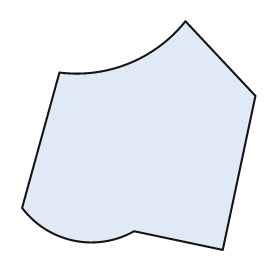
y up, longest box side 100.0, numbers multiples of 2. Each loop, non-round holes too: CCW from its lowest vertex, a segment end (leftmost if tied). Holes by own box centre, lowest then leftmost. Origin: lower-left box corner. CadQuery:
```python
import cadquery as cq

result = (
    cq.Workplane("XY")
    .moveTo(86.0, 0.0)
    .lineTo(100.0, 66.0)
    .lineTo(70.0, 98.0)
    .threePointArc((46.0, 80.0), (16.0, 76.0))
    .lineTo(0.0, 18.0)
    .threePointArc((22.0, 4.0), (48.0, 8.0))
    .close()
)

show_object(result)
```